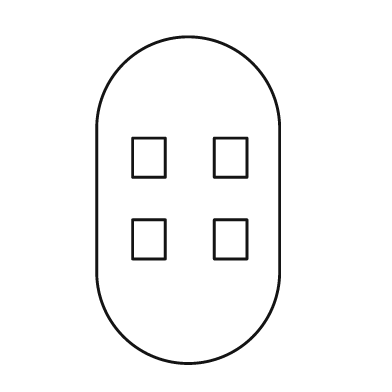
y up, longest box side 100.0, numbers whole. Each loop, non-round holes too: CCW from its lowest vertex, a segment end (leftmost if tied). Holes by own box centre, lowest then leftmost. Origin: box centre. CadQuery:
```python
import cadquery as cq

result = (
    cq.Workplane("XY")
    .moveTo(-28.0, -22.0)
    .threePointArc((0.0, -50.0), (28.0, -22.0))
    .lineTo(28.0, 22.0)
    .threePointArc((0.0, 50.0), (-28.0, 22.0))
    .close()
    .moveTo(-17.0, -18.0)
    .lineTo(-7.0, -18.0)
    .lineTo(-7.0, -6.0)
    .lineTo(-17.0, -6.0)
    .close()
    .moveTo(8.0, -18.0)
    .lineTo(18.0, -18.0)
    .lineTo(18.0, -6.0)
    .lineTo(8.0, -6.0)
    .close()
    .moveTo(-17.0, 7.0)
    .lineTo(-7.0, 7.0)
    .lineTo(-7.0, 19.0)
    .lineTo(-17.0, 19.0)
    .close()
    .moveTo(8.0, 7.0)
    .lineTo(18.0, 7.0)
    .lineTo(18.0, 19.0)
    .lineTo(8.0, 19.0)
    .close()
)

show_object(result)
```